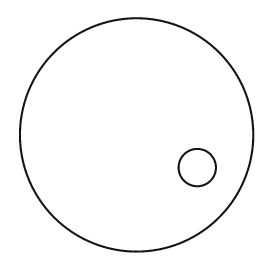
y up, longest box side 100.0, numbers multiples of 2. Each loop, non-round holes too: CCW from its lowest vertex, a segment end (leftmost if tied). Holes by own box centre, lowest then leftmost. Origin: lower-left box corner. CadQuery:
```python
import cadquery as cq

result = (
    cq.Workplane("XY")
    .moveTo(50.0, 50.0)
    .circle(50.0)
    .moveTo(76.0, 36.0)
    .circle(8.0)
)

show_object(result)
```